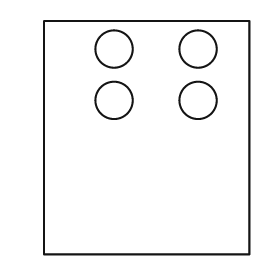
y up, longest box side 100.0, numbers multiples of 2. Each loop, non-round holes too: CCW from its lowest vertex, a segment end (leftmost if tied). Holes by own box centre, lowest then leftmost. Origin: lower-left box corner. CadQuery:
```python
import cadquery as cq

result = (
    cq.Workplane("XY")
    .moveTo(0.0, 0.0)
    .lineTo(88.0, 0.0)
    .lineTo(88.0, 100.0)
    .lineTo(0.0, 100.0)
    .close()
    .moveTo(30.0, 66.0)
    .circle(8.0)
    .moveTo(66.0, 66.0)
    .circle(8.0)
    .moveTo(30.0, 88.0)
    .circle(8.0)
    .moveTo(66.0, 88.0)
    .circle(8.0)
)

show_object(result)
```